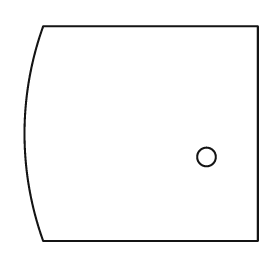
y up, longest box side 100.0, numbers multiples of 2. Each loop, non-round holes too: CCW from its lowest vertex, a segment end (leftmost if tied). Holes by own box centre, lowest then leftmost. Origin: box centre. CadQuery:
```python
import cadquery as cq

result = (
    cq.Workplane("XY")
    .moveTo(-42.0, -46.0)
    .lineTo(50.0, -46.0)
    .lineTo(50.0, 46.0)
    .lineTo(-42.0, 46.0)
    .threePointArc((-50.0, 0.0), (-42.0, -46.0))
    .close()
    .moveTo(28.0, -10.0)
    .circle(4.0)
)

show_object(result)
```